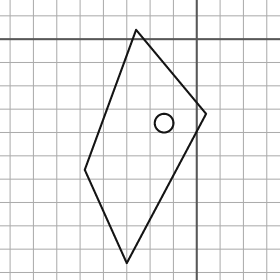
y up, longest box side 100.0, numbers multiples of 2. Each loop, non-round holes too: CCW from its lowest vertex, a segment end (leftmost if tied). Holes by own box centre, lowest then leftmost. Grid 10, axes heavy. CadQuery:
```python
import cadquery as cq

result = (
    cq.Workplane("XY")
    .moveTo(-30.0, -96.0)
    .lineTo(4.0, -32.0)
    .lineTo(-26.0, 4.0)
    .lineTo(-48.0, -56.0)
    .close()
    .moveTo(-14.0, -36.0)
    .circle(4.0)
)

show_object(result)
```